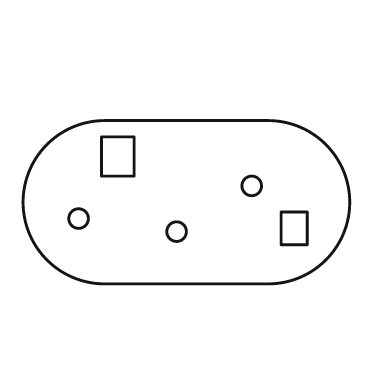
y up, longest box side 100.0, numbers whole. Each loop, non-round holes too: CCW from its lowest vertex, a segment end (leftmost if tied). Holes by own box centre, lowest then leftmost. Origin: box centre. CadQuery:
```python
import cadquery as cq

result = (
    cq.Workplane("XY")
    .moveTo(-25.0, -25.0)
    .lineTo(25.0, -25.0)
    .threePointArc((50.0, 0.0), (25.0, 25.0))
    .lineTo(-25.0, 25.0)
    .threePointArc((-50.0, 0.0), (-25.0, -25.0))
    .close()
    .moveTo(-3.0, -9.0)
    .circle(3.0)
    .moveTo(29.0, -13.0)
    .lineTo(37.0, -13.0)
    .lineTo(37.0, -3.0)
    .lineTo(29.0, -3.0)
    .close()
    .moveTo(-33.0, -5.0)
    .circle(3.0)
    .moveTo(20.0, 5.0)
    .circle(3.0)
    .moveTo(-26.0, 8.0)
    .lineTo(-16.0, 8.0)
    .lineTo(-16.0, 20.0)
    .lineTo(-26.0, 20.0)
    .close()
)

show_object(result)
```